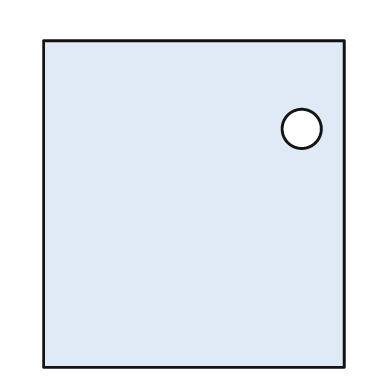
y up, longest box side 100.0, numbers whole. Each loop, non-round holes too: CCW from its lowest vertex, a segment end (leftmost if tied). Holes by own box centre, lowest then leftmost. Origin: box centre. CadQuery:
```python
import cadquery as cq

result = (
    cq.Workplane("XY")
    .moveTo(-46.0, -50.0)
    .lineTo(46.0, -50.0)
    .lineTo(46.0, 50.0)
    .lineTo(-46.0, 50.0)
    .close()
    .moveTo(33.0, 23.0)
    .circle(6.0)
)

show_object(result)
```